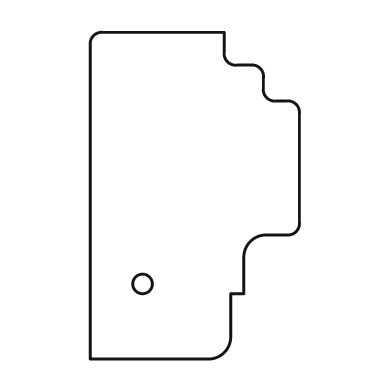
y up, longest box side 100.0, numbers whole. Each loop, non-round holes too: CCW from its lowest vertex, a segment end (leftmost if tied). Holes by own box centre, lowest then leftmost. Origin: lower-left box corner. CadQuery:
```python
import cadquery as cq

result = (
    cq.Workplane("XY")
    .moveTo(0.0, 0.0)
    .lineTo(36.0, 0.0)
    .threePointArc((41.0, 2.0), (43.0, 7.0))
    .lineTo(43.0, 20.0)
    .lineTo(47.0, 20.0)
    .lineTo(47.0, 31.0)
    .threePointArc((49.0, 36.0), (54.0, 38.0))
    .lineTo(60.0, 38.0)
    .threePointArc((63.0, 39.0), (64.0, 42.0))
    .lineTo(64.0, 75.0)
    .threePointArc((63.0, 78.0), (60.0, 79.0))
    .lineTo(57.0, 79.0)
    .threePointArc((54.0, 80.0), (53.0, 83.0))
    .lineTo(53.0, 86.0)
    .threePointArc((52.0, 89.0), (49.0, 90.0))
    .lineTo(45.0, 90.0)
    .threePointArc((42.0, 91.0), (41.0, 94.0))
    .lineTo(41.0, 100.0)
    .lineTo(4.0, 100.0)
    .threePointArc((1.0, 99.0), (0.0, 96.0))
    .close()
    .moveTo(16.0, 23.0)
    .circle(3.0)
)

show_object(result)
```